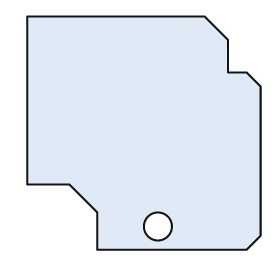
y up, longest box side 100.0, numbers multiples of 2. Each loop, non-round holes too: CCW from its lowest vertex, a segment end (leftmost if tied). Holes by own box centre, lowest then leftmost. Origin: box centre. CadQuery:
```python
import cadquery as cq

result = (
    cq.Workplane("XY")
    .moveTo(-20.0, -50.0)
    .lineTo(44.0, -50.0)
    .lineTo(50.0, -44.0)
    .lineTo(50.0, 20.0)
    .lineTo(44.0, 26.0)
    .lineTo(36.0, 26.0)
    .lineTo(36.0, 40.0)
    .lineTo(26.0, 50.0)
    .lineTo(-50.0, 50.0)
    .lineTo(-50.0, -22.0)
    .lineTo(-32.0, -22.0)
    .lineTo(-20.0, -34.0)
    .close()
    .moveTo(6.0, -40.0)
    .circle(6.0)
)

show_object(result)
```